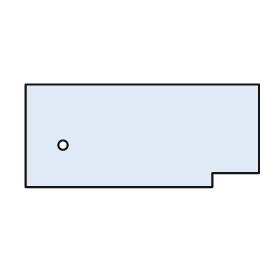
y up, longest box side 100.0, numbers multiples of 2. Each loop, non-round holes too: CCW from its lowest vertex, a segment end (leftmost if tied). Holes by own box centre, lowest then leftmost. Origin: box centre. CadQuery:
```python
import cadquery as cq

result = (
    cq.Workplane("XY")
    .moveTo(-50.0, -22.0)
    .lineTo(30.0, -22.0)
    .lineTo(30.0, -16.0)
    .lineTo(50.0, -16.0)
    .lineTo(50.0, 22.0)
    .lineTo(-50.0, 22.0)
    .close()
    .moveTo(-34.0, -4.0)
    .circle(2.0)
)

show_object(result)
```